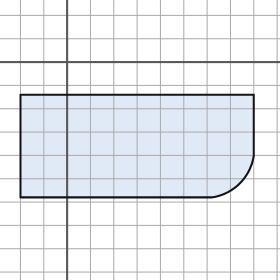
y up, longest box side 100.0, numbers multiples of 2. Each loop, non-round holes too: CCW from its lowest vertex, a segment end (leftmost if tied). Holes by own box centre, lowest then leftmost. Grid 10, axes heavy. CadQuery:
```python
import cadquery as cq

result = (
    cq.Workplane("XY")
    .moveTo(-20.0, -58.0)
    .lineTo(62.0, -58.0)
    .threePointArc((74.0, -52.0), (80.0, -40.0))
    .lineTo(80.0, -14.0)
    .lineTo(-20.0, -14.0)
    .close()
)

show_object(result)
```